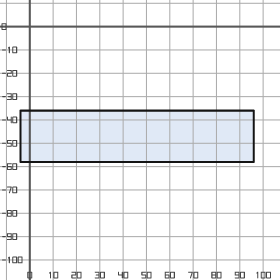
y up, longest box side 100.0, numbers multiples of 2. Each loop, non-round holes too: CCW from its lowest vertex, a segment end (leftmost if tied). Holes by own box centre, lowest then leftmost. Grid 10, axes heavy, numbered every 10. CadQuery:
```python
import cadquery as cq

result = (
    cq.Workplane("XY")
    .moveTo(-4.0, -58.0)
    .lineTo(96.0, -58.0)
    .lineTo(96.0, -36.0)
    .lineTo(-4.0, -36.0)
    .close()
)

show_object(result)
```